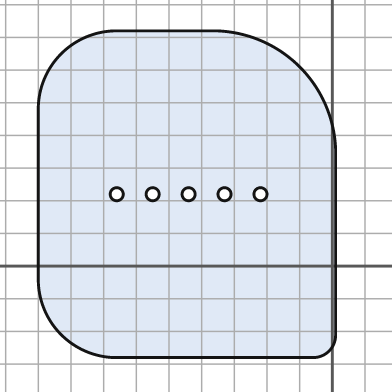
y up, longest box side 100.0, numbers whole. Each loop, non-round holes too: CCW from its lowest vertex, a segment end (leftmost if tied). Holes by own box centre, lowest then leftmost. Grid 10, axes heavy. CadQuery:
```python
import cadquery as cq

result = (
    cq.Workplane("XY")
    .moveTo(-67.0, -28.0)
    .lineTo(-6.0, -28.0)
    .threePointArc((-1.0, -26.0), (1.0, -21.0))
    .lineTo(1.0, 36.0)
    .threePointArc((-10.0, 61.0), (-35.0, 72.0))
    .lineTo(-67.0, 72.0)
    .threePointArc((-83.0, 65.0), (-90.0, 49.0))
    .lineTo(-90.0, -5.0)
    .threePointArc((-83.0, -21.0), (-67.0, -28.0))
    .close()
    .moveTo(-66.0, 22.0)
    .circle(2.0)
    .moveTo(-55.0, 22.0)
    .circle(2.0)
    .moveTo(-44.0, 22.0)
    .circle(2.0)
    .moveTo(-33.0, 22.0)
    .circle(2.0)
    .moveTo(-22.0, 22.0)
    .circle(2.0)
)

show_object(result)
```